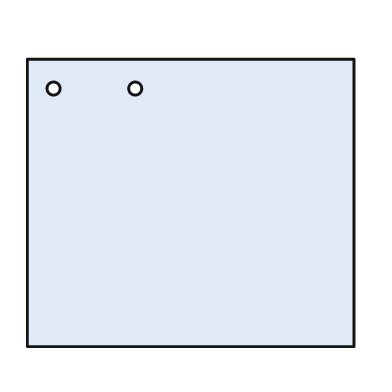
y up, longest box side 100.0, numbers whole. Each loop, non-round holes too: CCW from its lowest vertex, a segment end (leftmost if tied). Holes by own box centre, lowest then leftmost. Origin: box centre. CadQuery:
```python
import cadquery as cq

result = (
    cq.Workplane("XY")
    .moveTo(-50.0, -44.0)
    .lineTo(50.0, -44.0)
    .lineTo(50.0, 44.0)
    .lineTo(-50.0, 44.0)
    .close()
    .moveTo(-42.0, 35.0)
    .circle(2.0)
    .moveTo(-17.0, 35.0)
    .circle(2.0)
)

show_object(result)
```